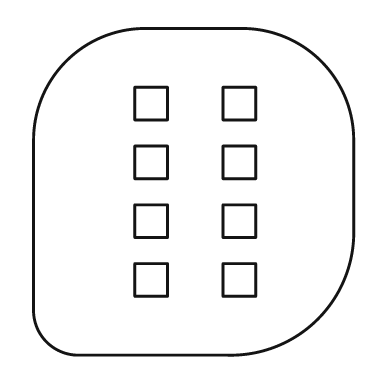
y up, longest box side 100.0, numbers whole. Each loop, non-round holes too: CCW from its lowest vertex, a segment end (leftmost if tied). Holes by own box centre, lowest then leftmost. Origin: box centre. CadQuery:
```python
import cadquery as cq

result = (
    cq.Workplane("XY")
    .moveTo(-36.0, -50.0)
    .lineTo(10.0, -50.0)
    .threePointArc((38.0, -39.0), (49.0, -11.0))
    .lineTo(49.0, 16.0)
    .threePointArc((39.0, 40.0), (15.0, 50.0))
    .lineTo(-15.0, 50.0)
    .threePointArc((-39.0, 40.0), (-49.0, 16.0))
    .lineTo(-49.0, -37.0)
    .threePointArc((-45.0, -46.0), (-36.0, -50.0))
    .close()
    .moveTo(-18.0, -32.0)
    .lineTo(-8.0, -32.0)
    .lineTo(-8.0, -22.0)
    .lineTo(-18.0, -22.0)
    .close()
    .moveTo(9.0, -32.0)
    .lineTo(19.0, -32.0)
    .lineTo(19.0, -22.0)
    .lineTo(9.0, -22.0)
    .close()
    .moveTo(-18.0, -14.0)
    .lineTo(-8.0, -14.0)
    .lineTo(-8.0, -4.0)
    .lineTo(-18.0, -4.0)
    .close()
    .moveTo(9.0, -14.0)
    .lineTo(19.0, -14.0)
    .lineTo(19.0, -4.0)
    .lineTo(9.0, -4.0)
    .close()
    .moveTo(-18.0, 4.0)
    .lineTo(-8.0, 4.0)
    .lineTo(-8.0, 14.0)
    .lineTo(-18.0, 14.0)
    .close()
    .moveTo(9.0, 4.0)
    .lineTo(19.0, 4.0)
    .lineTo(19.0, 14.0)
    .lineTo(9.0, 14.0)
    .close()
    .moveTo(-18.0, 22.0)
    .lineTo(-8.0, 22.0)
    .lineTo(-8.0, 32.0)
    .lineTo(-18.0, 32.0)
    .close()
    .moveTo(9.0, 22.0)
    .lineTo(19.0, 22.0)
    .lineTo(19.0, 32.0)
    .lineTo(9.0, 32.0)
    .close()
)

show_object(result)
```